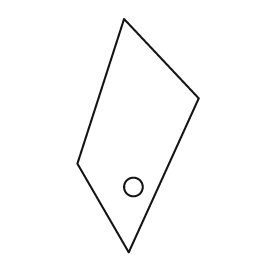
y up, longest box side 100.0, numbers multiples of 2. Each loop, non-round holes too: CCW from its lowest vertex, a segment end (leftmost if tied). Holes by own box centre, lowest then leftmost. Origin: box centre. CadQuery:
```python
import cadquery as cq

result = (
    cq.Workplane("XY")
    .moveTo(-4.0, -50.0)
    .lineTo(26.0, 16.0)
    .lineTo(-6.0, 50.0)
    .lineTo(-26.0, -12.0)
    .close()
    .moveTo(-2.0, -22.0)
    .circle(4.0)
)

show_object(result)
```